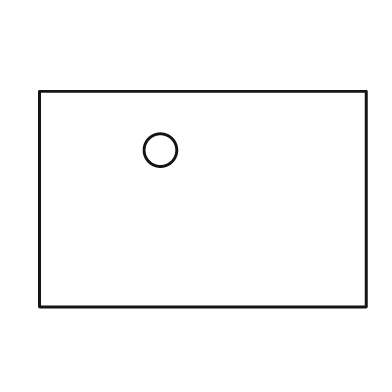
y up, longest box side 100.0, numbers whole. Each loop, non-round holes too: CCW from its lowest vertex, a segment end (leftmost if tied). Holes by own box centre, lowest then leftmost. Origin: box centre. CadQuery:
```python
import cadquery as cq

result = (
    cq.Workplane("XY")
    .moveTo(-50.0, -33.0)
    .lineTo(50.0, -33.0)
    .lineTo(50.0, 33.0)
    .lineTo(-50.0, 33.0)
    .close()
    .moveTo(-13.0, 15.0)
    .circle(5.0)
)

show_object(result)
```